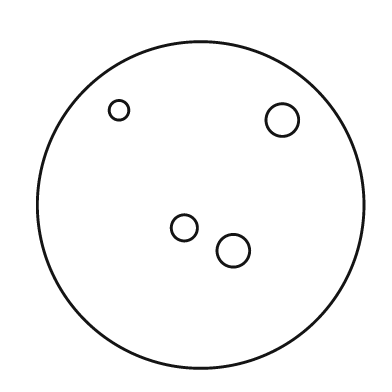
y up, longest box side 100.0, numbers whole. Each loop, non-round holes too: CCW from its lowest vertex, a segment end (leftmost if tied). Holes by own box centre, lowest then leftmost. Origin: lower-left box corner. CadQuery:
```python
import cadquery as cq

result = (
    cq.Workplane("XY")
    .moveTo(50.0, 50.0)
    .circle(50.0)
    .moveTo(60.0, 36.0)
    .circle(5.0)
    .moveTo(45.0, 43.0)
    .circle(4.0)
    .moveTo(75.0, 76.0)
    .circle(5.0)
    .moveTo(25.0, 79.0)
    .circle(3.0)
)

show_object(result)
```